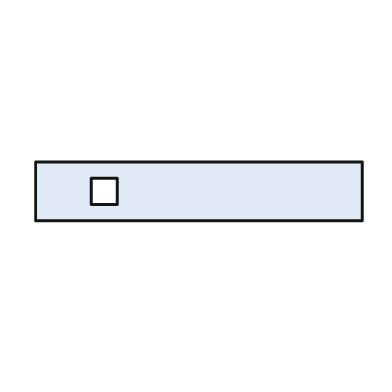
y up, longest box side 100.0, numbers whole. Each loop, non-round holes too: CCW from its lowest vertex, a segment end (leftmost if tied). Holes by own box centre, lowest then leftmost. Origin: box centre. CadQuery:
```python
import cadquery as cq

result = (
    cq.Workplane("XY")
    .moveTo(-50.0, -9.0)
    .lineTo(50.0, -9.0)
    .lineTo(50.0, 9.0)
    .lineTo(-50.0, 9.0)
    .close()
    .moveTo(-33.0, -4.0)
    .lineTo(-25.0, -4.0)
    .lineTo(-25.0, 4.0)
    .lineTo(-33.0, 4.0)
    .close()
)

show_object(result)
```